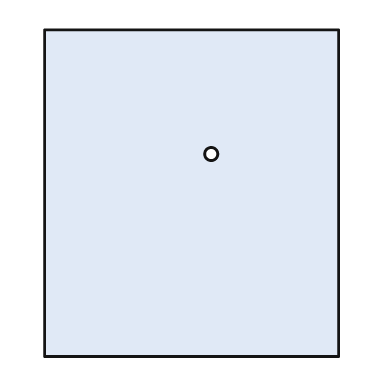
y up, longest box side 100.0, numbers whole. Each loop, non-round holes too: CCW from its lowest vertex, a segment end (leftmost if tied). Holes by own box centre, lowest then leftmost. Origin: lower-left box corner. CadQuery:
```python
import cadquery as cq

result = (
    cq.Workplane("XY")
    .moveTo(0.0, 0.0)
    .lineTo(90.0, 0.0)
    .lineTo(90.0, 100.0)
    .lineTo(0.0, 100.0)
    .close()
    .moveTo(51.0, 62.0)
    .circle(2.0)
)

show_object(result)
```